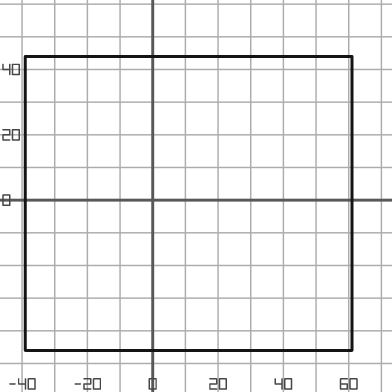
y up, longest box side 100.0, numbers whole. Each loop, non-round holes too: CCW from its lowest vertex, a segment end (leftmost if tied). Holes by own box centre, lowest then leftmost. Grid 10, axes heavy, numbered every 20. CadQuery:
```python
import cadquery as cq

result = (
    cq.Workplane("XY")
    .moveTo(-39.0, -46.0)
    .lineTo(61.0, -46.0)
    .lineTo(61.0, 44.0)
    .lineTo(-39.0, 44.0)
    .close()
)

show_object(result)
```